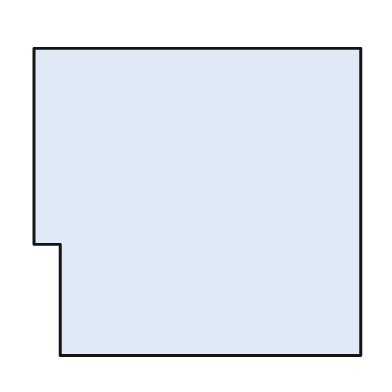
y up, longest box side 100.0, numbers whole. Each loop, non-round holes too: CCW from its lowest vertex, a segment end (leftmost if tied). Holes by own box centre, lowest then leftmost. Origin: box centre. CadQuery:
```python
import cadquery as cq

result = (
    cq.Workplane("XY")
    .moveTo(-42.0, -47.0)
    .lineTo(50.0, -47.0)
    .lineTo(50.0, 47.0)
    .lineTo(-50.0, 47.0)
    .lineTo(-50.0, -13.0)
    .lineTo(-42.0, -13.0)
    .close()
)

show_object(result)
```